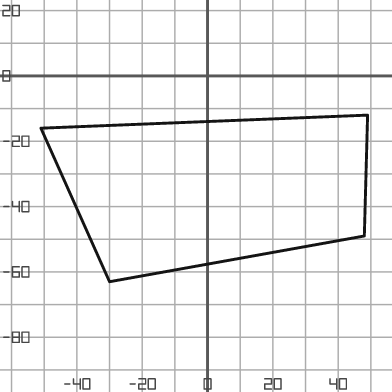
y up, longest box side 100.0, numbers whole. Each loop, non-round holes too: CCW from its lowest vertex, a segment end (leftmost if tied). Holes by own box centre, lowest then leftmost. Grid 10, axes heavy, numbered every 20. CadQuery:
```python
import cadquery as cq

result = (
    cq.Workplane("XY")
    .moveTo(-30.0, -63.0)
    .lineTo(48.0, -49.0)
    .lineTo(49.0, -12.0)
    .lineTo(-51.0, -16.0)
    .close()
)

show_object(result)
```